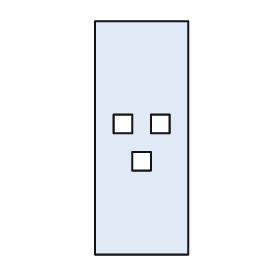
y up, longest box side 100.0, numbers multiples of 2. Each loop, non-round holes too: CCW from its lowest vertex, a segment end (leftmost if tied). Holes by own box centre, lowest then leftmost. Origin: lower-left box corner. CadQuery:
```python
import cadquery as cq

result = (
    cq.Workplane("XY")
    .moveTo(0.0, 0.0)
    .lineTo(40.0, 0.0)
    .lineTo(40.0, 100.0)
    .lineTo(0.0, 100.0)
    .close()
    .moveTo(16.0, 36.0)
    .lineTo(24.0, 36.0)
    .lineTo(24.0, 44.0)
    .lineTo(16.0, 44.0)
    .close()
    .moveTo(8.0, 52.0)
    .lineTo(16.0, 52.0)
    .lineTo(16.0, 60.0)
    .lineTo(8.0, 60.0)
    .close()
    .moveTo(24.0, 52.0)
    .lineTo(32.0, 52.0)
    .lineTo(32.0, 60.0)
    .lineTo(24.0, 60.0)
    .close()
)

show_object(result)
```